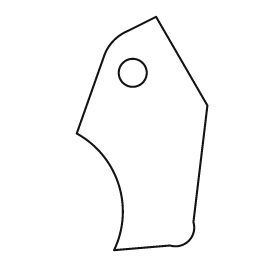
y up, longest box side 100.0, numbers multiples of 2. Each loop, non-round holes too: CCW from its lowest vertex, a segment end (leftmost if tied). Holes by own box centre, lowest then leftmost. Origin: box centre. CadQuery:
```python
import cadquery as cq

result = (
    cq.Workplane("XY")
    .moveTo(-12.0, -50.0)
    .lineTo(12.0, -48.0)
    .threePointArc((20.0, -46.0), (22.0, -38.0))
    .lineTo(28.0, 12.0)
    .lineTo(6.0, 50.0)
    .lineTo(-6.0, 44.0)
    .threePointArc((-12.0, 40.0), (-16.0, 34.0))
    .lineTo(-28.0, 0.0)
    .threePointArc((-10.0, -22.0), (-12.0, -50.0))
    .close()
    .moveTo(-4.0, 26.0)
    .circle(6.0)
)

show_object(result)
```